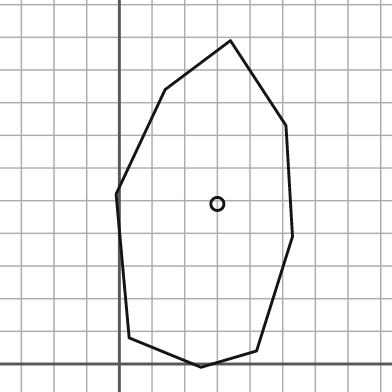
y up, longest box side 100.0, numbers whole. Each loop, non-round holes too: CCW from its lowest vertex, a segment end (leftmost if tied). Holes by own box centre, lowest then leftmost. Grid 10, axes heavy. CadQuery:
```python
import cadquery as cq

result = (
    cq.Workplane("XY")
    .moveTo(25.0, -1.0)
    .lineTo(42.0, 4.0)
    .lineTo(53.0, 39.0)
    .lineTo(51.0, 73.0)
    .lineTo(34.0, 99.0)
    .lineTo(14.0, 84.0)
    .lineTo(-1.0, 52.0)
    .lineTo(3.0, 8.0)
    .close()
    .moveTo(30.0, 49.0)
    .circle(2.0)
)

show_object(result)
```